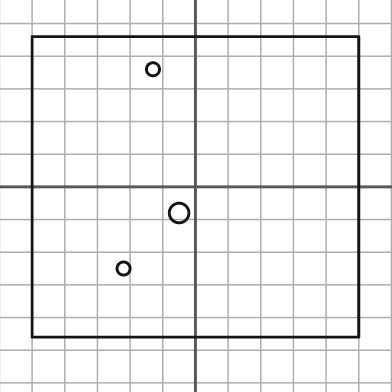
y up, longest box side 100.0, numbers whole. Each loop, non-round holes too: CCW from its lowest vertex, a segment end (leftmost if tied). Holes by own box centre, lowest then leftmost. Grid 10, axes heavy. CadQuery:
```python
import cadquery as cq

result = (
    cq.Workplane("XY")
    .moveTo(-50.0, -46.0)
    .lineTo(50.0, -46.0)
    .lineTo(50.0, 46.0)
    .lineTo(-50.0, 46.0)
    .close()
    .moveTo(-22.0, -25.0)
    .circle(2.0)
    .moveTo(-5.0, -8.0)
    .circle(3.0)
    .moveTo(-13.0, 36.0)
    .circle(2.0)
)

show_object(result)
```